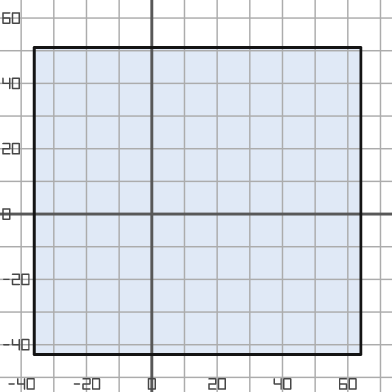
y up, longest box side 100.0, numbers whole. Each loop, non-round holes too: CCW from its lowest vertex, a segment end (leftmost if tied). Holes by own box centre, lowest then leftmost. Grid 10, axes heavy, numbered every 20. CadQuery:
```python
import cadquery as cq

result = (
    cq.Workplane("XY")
    .moveTo(-36.0, -43.0)
    .lineTo(64.0, -43.0)
    .lineTo(64.0, 51.0)
    .lineTo(-36.0, 51.0)
    .close()
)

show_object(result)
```